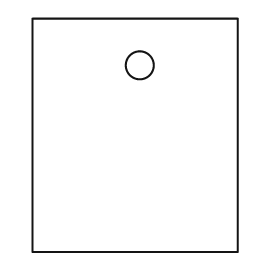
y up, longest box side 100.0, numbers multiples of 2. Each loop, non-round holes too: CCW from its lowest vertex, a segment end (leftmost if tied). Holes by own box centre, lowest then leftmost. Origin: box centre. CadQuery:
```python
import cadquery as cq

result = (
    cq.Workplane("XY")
    .moveTo(-44.0, -50.0)
    .lineTo(44.0, -50.0)
    .lineTo(44.0, 50.0)
    .lineTo(-44.0, 50.0)
    .close()
    .moveTo(2.0, 30.0)
    .circle(6.0)
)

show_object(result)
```